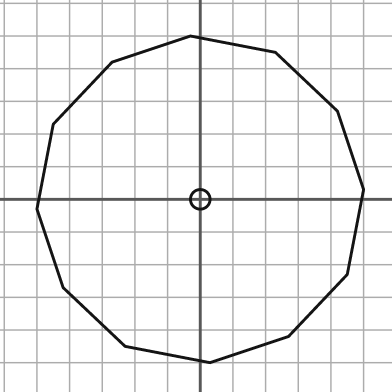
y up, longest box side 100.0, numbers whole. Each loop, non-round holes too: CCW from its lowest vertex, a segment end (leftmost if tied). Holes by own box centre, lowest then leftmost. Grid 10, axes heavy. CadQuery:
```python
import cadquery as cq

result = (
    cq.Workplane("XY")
    .moveTo(3.0, -50.0)
    .lineTo(27.0, -42.0)
    .lineTo(45.0, -23.0)
    .lineTo(50.0, 3.0)
    .lineTo(42.0, 27.0)
    .lineTo(23.0, 45.0)
    .lineTo(-3.0, 50.0)
    .lineTo(-27.0, 42.0)
    .lineTo(-45.0, 23.0)
    .lineTo(-50.0, -3.0)
    .lineTo(-42.0, -27.0)
    .lineTo(-23.0, -45.0)
    .close()
    .moveTo(0.0, 0.0)
    .circle(3.0)
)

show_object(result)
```